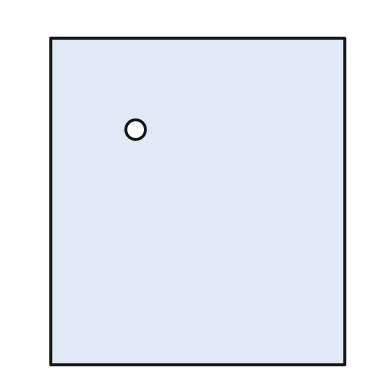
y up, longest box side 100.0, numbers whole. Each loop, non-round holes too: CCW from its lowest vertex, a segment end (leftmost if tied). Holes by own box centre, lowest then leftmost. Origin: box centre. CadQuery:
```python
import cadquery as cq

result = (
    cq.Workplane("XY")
    .moveTo(-45.0, -50.0)
    .lineTo(45.0, -50.0)
    .lineTo(45.0, 50.0)
    .lineTo(-45.0, 50.0)
    .close()
    .moveTo(-19.0, 22.0)
    .circle(3.0)
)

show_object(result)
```